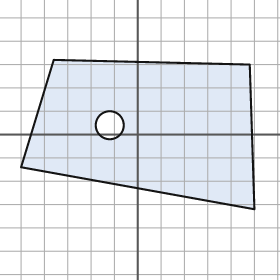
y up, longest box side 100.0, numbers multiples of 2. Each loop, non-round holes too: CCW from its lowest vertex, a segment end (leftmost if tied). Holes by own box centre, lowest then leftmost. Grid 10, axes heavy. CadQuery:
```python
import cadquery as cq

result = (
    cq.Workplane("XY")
    .moveTo(50.0, -32.0)
    .lineTo(48.0, 30.0)
    .lineTo(-36.0, 32.0)
    .lineTo(-50.0, -14.0)
    .close()
    .moveTo(-12.0, 4.0)
    .circle(6.0)
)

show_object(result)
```